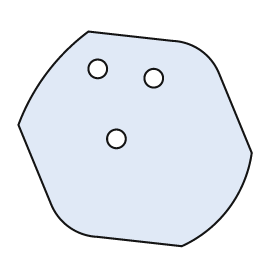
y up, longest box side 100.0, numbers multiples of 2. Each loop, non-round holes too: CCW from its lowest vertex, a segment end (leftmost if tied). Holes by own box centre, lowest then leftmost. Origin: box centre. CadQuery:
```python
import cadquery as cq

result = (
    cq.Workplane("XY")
    .moveTo(20.0, -46.0)
    .threePointArc((40.0, -30.0), (50.0, -6.0))
    .lineTo(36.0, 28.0)
    .threePointArc((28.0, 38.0), (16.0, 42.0))
    .lineTo(-20.0, 46.0)
    .threePointArc((-38.0, 28.0), (-50.0, 6.0))
    .lineTo(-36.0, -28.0)
    .threePointArc((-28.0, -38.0), (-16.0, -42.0))
    .close()
    .moveTo(-8.0, 0.0)
    .circle(4.0)
    .moveTo(8.0, 26.0)
    .circle(4.0)
    .moveTo(-16.0, 30.0)
    .circle(4.0)
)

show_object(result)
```